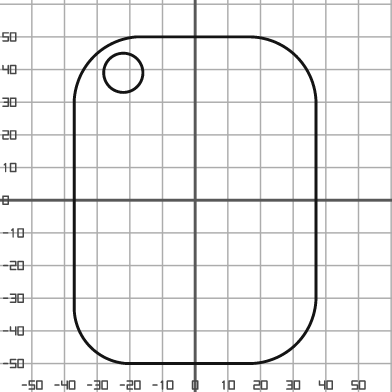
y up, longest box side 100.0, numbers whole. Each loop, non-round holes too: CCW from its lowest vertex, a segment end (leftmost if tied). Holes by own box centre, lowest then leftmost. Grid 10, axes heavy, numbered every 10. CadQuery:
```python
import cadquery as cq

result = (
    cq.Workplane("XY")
    .moveTo(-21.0, -50.0)
    .lineTo(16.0, -50.0)
    .threePointArc((31.0, -44.0), (37.0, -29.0))
    .lineTo(37.0, 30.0)
    .threePointArc((31.0, 44.0), (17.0, 50.0))
    .lineTo(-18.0, 50.0)
    .threePointArc((-31.0, 44.0), (-37.0, 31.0))
    .lineTo(-37.0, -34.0)
    .threePointArc((-32.0, -45.0), (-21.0, -50.0))
    .close()
    .moveTo(-22.0, 39.0)
    .circle(6.0)
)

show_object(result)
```